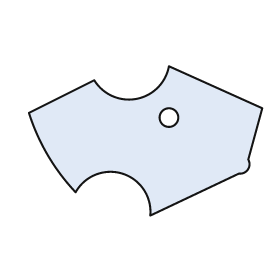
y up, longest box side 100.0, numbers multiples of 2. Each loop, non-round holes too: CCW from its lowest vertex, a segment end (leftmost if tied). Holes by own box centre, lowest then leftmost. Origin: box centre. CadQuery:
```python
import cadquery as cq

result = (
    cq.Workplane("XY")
    .moveTo(2.0, -32.0)
    .lineTo(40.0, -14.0)
    .threePointArc((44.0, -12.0), (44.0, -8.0))
    .lineTo(50.0, 14.0)
    .lineTo(10.0, 32.0)
    .threePointArc((-4.0, 18.0), (-22.0, 26.0))
    .lineTo(-50.0, 12.0)
    .threePointArc((-42.0, -6.0), (-30.0, -22.0))
    .threePointArc((-10.0, -14.0), (2.0, -32.0))
    .close()
    .moveTo(10.0, 10.0)
    .circle(4.0)
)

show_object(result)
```